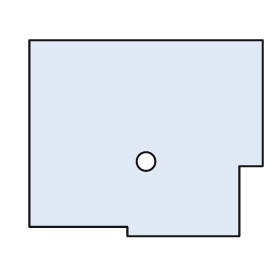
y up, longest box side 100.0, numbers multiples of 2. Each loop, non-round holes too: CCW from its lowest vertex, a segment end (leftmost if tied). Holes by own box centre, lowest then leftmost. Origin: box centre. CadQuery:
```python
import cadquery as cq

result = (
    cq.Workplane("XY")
    .moveTo(-8.0, -42.0)
    .lineTo(40.0, -42.0)
    .lineTo(40.0, -12.0)
    .lineTo(50.0, -12.0)
    .lineTo(50.0, 42.0)
    .lineTo(-50.0, 42.0)
    .lineTo(-50.0, -38.0)
    .lineTo(-8.0, -38.0)
    .close()
    .moveTo(0.0, -10.0)
    .circle(4.0)
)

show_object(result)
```